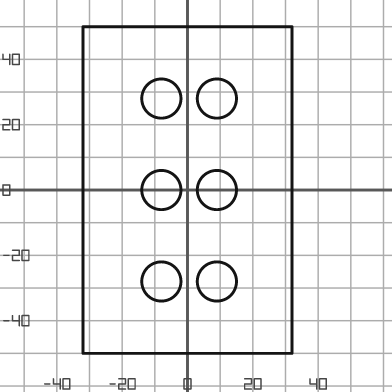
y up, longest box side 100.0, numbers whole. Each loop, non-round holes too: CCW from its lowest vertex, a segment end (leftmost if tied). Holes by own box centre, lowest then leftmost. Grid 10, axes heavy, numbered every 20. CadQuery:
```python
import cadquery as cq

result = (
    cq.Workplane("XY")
    .moveTo(-32.0, -50.0)
    .lineTo(32.0, -50.0)
    .lineTo(32.0, 50.0)
    .lineTo(-32.0, 50.0)
    .close()
    .moveTo(-8.0, -28.0)
    .circle(6.0)
    .moveTo(9.0, -28.0)
    .circle(6.0)
    .moveTo(-8.0, 0.0)
    .circle(6.0)
    .moveTo(9.0, 0.0)
    .circle(6.0)
    .moveTo(-8.0, 28.0)
    .circle(6.0)
    .moveTo(9.0, 28.0)
    .circle(6.0)
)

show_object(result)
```